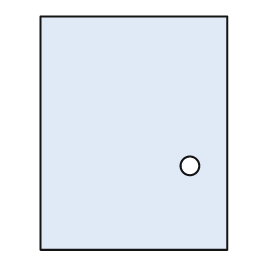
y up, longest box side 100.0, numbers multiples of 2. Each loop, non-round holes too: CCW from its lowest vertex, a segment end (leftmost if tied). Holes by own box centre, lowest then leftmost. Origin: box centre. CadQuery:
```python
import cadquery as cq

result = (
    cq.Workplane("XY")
    .moveTo(-40.0, -50.0)
    .lineTo(40.0, -50.0)
    .lineTo(40.0, 50.0)
    .lineTo(-40.0, 50.0)
    .close()
    .moveTo(24.0, -14.0)
    .circle(4.0)
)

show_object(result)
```